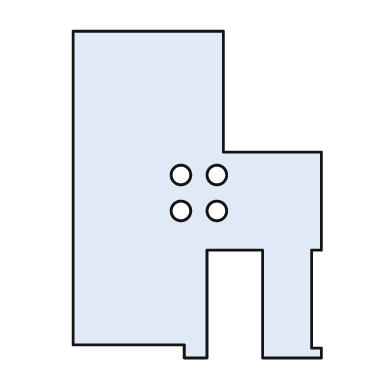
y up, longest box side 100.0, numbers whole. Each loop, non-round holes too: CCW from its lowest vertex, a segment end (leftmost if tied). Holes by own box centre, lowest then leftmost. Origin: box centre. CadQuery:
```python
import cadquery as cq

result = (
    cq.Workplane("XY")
    .moveTo(-4.0, -50.0)
    .lineTo(3.0, -50.0)
    .lineTo(3.0, -17.0)
    .lineTo(20.0, -17.0)
    .lineTo(20.0, -50.0)
    .lineTo(38.0, -50.0)
    .lineTo(38.0, -47.0)
    .lineTo(35.0, -47.0)
    .lineTo(35.0, -17.0)
    .lineTo(38.0, -17.0)
    .lineTo(38.0, 13.0)
    .lineTo(8.0, 13.0)
    .lineTo(8.0, 50.0)
    .lineTo(-38.0, 50.0)
    .lineTo(-38.0, -46.0)
    .lineTo(-4.0, -46.0)
    .close()
    .moveTo(-5.0, -5.0)
    .circle(3.0)
    .moveTo(6.0, -5.0)
    .circle(3.0)
    .moveTo(-5.0, 6.0)
    .circle(3.0)
    .moveTo(6.0, 6.0)
    .circle(3.0)
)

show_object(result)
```